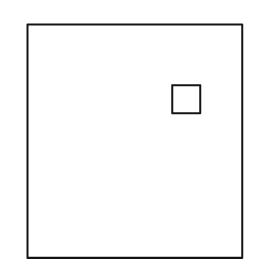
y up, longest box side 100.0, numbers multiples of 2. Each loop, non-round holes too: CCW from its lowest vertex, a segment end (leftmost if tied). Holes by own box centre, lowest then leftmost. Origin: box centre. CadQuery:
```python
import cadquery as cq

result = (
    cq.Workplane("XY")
    .moveTo(-46.0, -50.0)
    .lineTo(46.0, -50.0)
    .lineTo(46.0, 50.0)
    .lineTo(-46.0, 50.0)
    .close()
    .moveTo(16.0, 12.0)
    .lineTo(28.0, 12.0)
    .lineTo(28.0, 24.0)
    .lineTo(16.0, 24.0)
    .close()
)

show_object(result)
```